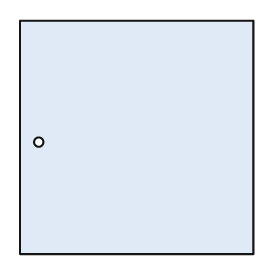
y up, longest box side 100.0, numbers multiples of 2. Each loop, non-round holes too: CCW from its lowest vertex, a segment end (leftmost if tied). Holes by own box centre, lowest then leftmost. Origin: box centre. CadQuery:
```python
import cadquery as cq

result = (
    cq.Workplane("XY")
    .moveTo(-50.0, -50.0)
    .lineTo(50.0, -50.0)
    .lineTo(50.0, 50.0)
    .lineTo(-50.0, 50.0)
    .close()
    .moveTo(-42.0, -2.0)
    .circle(2.0)
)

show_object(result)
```